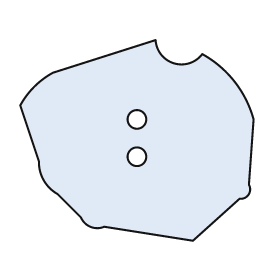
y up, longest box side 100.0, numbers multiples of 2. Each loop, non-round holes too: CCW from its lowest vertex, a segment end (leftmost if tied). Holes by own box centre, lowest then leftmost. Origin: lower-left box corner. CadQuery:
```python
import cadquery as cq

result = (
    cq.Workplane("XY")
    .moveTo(74.0, 0.0)
    .lineTo(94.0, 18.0)
    .threePointArc((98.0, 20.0), (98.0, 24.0))
    .lineTo(100.0, 52.0)
    .threePointArc((92.0, 68.0), (78.0, 80.0))
    .threePointArc((66.0, 76.0), (58.0, 86.0))
    .lineTo(14.0, 72.0)
    .threePointArc((6.0, 66.0), (0.0, 58.0))
    .lineTo(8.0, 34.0)
    .threePointArc((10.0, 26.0), (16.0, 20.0))
    .lineTo(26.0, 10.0)
    .threePointArc((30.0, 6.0), (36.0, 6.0))
    .close()
    .moveTo(50.0, 36.0)
    .circle(4.0)
    .moveTo(50.0, 52.0)
    .circle(4.0)
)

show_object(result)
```